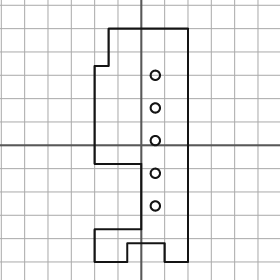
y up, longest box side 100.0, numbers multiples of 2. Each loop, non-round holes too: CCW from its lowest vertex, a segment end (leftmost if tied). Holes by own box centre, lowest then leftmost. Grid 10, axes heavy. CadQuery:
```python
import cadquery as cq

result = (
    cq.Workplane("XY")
    .moveTo(-20.0, -50.0)
    .lineTo(-6.0, -50.0)
    .lineTo(-6.0, -42.0)
    .lineTo(10.0, -42.0)
    .lineTo(10.0, -50.0)
    .lineTo(20.0, -50.0)
    .lineTo(20.0, 50.0)
    .lineTo(-14.0, 50.0)
    .lineTo(-14.0, 34.0)
    .lineTo(-20.0, 34.0)
    .lineTo(-20.0, -8.0)
    .lineTo(0.0, -8.0)
    .lineTo(0.0, -36.0)
    .lineTo(-20.0, -36.0)
    .close()
    .moveTo(6.0, -26.0)
    .circle(2.0)
    .moveTo(6.0, -12.0)
    .circle(2.0)
    .moveTo(6.0, 2.0)
    .circle(2.0)
    .moveTo(6.0, 16.0)
    .circle(2.0)
    .moveTo(6.0, 30.0)
    .circle(2.0)
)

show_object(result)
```